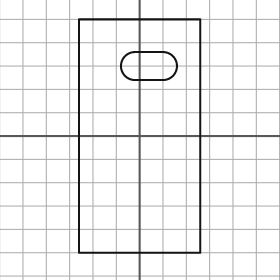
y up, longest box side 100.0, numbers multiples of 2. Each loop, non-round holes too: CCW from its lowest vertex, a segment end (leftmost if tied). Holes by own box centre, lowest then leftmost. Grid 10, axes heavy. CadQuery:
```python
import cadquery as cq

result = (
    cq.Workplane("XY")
    .moveTo(-26.0, -50.0)
    .lineTo(26.0, -50.0)
    .lineTo(26.0, 50.0)
    .lineTo(-26.0, 50.0)
    .close()
    .moveTo(-2.0, 24.0)
    .lineTo(10.0, 24.0)
    .threePointArc((16.0, 30.0), (10.0, 36.0))
    .lineTo(-2.0, 36.0)
    .threePointArc((-8.0, 30.0), (-2.0, 24.0))
    .close()
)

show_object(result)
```